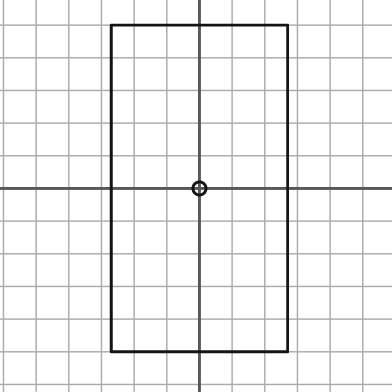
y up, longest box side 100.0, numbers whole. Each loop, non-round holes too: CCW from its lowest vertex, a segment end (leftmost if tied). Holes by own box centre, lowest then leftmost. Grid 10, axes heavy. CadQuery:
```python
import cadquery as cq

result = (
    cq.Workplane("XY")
    .moveTo(-27.0, -50.0)
    .lineTo(27.0, -50.0)
    .lineTo(27.0, 50.0)
    .lineTo(-27.0, 50.0)
    .close()
    .moveTo(0.0, 0.0)
    .circle(2.0)
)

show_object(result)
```